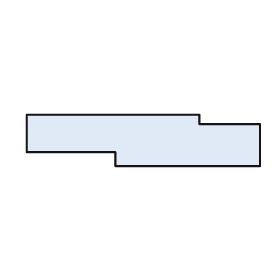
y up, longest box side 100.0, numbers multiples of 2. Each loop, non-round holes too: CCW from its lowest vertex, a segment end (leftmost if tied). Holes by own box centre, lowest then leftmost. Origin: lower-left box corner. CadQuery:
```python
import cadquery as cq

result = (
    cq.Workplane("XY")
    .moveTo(38.0, 0.0)
    .lineTo(100.0, 0.0)
    .lineTo(100.0, 18.0)
    .lineTo(74.0, 18.0)
    .lineTo(74.0, 22.0)
    .lineTo(0.0, 22.0)
    .lineTo(0.0, 6.0)
    .lineTo(38.0, 6.0)
    .close()
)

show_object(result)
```